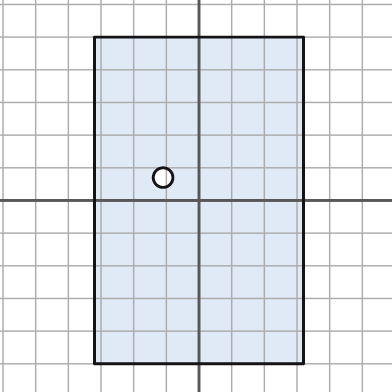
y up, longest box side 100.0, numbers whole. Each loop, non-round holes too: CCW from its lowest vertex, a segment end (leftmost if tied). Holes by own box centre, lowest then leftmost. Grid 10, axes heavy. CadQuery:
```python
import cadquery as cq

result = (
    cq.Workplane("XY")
    .moveTo(-32.0, -50.0)
    .lineTo(32.0, -50.0)
    .lineTo(32.0, 50.0)
    .lineTo(-32.0, 50.0)
    .close()
    .moveTo(-11.0, 7.0)
    .circle(3.0)
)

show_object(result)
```